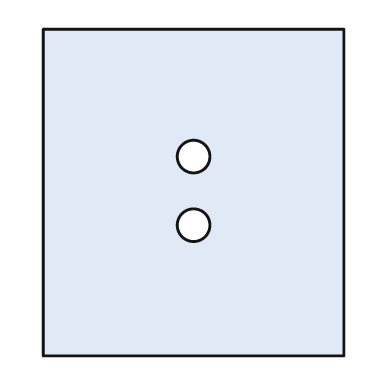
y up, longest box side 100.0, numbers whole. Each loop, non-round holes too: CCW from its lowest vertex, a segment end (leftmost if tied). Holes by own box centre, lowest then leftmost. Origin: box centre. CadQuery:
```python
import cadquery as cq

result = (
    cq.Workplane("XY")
    .moveTo(-46.0, -50.0)
    .lineTo(46.0, -50.0)
    .lineTo(46.0, 50.0)
    .lineTo(-46.0, 50.0)
    .close()
    .moveTo(0.0, -10.0)
    .circle(5.0)
    .moveTo(0.0, 11.0)
    .circle(5.0)
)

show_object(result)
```